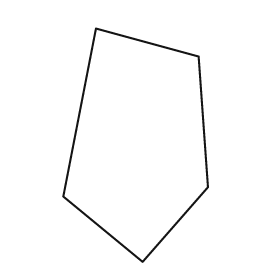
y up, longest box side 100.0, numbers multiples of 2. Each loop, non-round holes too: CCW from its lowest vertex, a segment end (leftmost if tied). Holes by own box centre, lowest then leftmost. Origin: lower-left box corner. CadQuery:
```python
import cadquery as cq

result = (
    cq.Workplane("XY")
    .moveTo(34.0, 0.0)
    .lineTo(62.0, 32.0)
    .lineTo(58.0, 88.0)
    .lineTo(14.0, 100.0)
    .lineTo(0.0, 28.0)
    .close()
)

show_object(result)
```